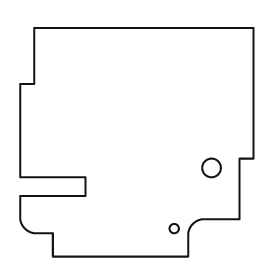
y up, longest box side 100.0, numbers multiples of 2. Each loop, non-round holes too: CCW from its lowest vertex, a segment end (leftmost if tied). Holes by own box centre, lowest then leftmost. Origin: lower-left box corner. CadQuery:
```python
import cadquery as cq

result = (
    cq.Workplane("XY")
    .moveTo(14.0, 0.0)
    .lineTo(72.0, 0.0)
    .lineTo(72.0, 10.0)
    .threePointArc((74.0, 14.0), (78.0, 16.0))
    .lineTo(94.0, 16.0)
    .lineTo(94.0, 42.0)
    .lineTo(100.0, 42.0)
    .lineTo(100.0, 98.0)
    .lineTo(6.0, 98.0)
    .lineTo(6.0, 74.0)
    .lineTo(0.0, 74.0)
    .lineTo(0.0, 34.0)
    .lineTo(28.0, 34.0)
    .lineTo(28.0, 26.0)
    .lineTo(0.0, 26.0)
    .lineTo(0.0, 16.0)
    .threePointArc((2.0, 12.0), (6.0, 10.0))
    .lineTo(14.0, 10.0)
    .close()
    .moveTo(66.0, 12.0)
    .circle(2.0)
    .moveTo(82.0, 38.0)
    .circle(4.0)
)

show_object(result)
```